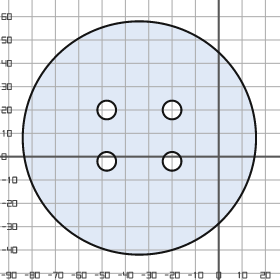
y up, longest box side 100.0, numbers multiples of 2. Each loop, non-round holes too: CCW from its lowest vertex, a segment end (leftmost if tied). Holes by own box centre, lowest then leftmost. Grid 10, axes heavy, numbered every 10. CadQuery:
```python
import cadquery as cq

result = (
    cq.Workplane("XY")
    .moveTo(-34.0, 8.0)
    .circle(50.0)
    .moveTo(-48.0, -2.0)
    .circle(4.0)
    .moveTo(-20.0, -2.0)
    .circle(4.0)
    .moveTo(-48.0, 20.0)
    .circle(4.0)
    .moveTo(-20.0, 20.0)
    .circle(4.0)
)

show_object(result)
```